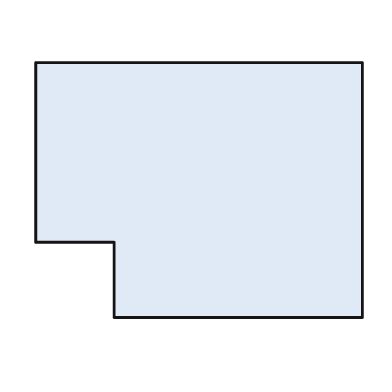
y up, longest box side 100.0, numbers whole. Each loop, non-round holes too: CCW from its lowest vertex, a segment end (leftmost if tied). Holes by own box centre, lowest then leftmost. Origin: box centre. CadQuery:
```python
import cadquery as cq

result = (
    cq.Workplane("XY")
    .moveTo(-26.0, -39.0)
    .lineTo(50.0, -39.0)
    .lineTo(50.0, 39.0)
    .lineTo(-50.0, 39.0)
    .lineTo(-50.0, -16.0)
    .lineTo(-26.0, -16.0)
    .close()
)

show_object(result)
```